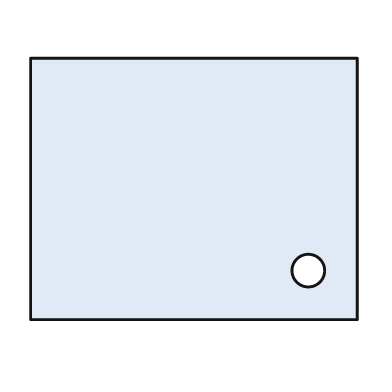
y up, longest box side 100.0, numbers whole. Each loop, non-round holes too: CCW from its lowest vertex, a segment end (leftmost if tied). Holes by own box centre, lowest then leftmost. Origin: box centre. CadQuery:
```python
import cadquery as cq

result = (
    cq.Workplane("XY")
    .moveTo(-50.0, -40.0)
    .lineTo(50.0, -40.0)
    .lineTo(50.0, 40.0)
    .lineTo(-50.0, 40.0)
    .close()
    .moveTo(35.0, -25.0)
    .circle(5.0)
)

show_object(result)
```